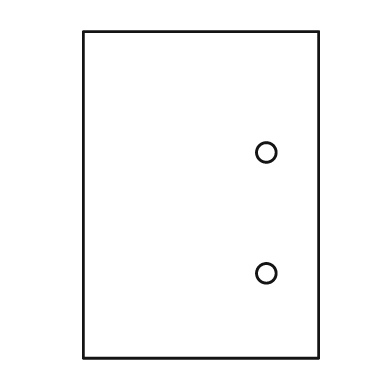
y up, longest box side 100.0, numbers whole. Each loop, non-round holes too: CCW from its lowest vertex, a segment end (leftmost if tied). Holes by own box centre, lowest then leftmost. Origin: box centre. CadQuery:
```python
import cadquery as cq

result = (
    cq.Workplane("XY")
    .moveTo(-36.0, -50.0)
    .lineTo(36.0, -50.0)
    .lineTo(36.0, 50.0)
    .lineTo(-36.0, 50.0)
    .close()
    .moveTo(20.0, -24.0)
    .circle(3.0)
    .moveTo(20.0, 13.0)
    .circle(3.0)
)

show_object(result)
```